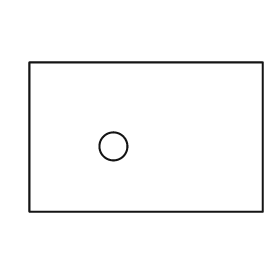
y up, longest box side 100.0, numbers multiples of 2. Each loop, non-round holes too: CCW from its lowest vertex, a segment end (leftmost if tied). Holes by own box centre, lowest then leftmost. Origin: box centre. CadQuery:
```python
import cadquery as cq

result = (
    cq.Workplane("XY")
    .moveTo(-50.0, -32.0)
    .lineTo(50.0, -32.0)
    .lineTo(50.0, 32.0)
    .lineTo(-50.0, 32.0)
    .close()
    .moveTo(-14.0, -4.0)
    .circle(6.0)
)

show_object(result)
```